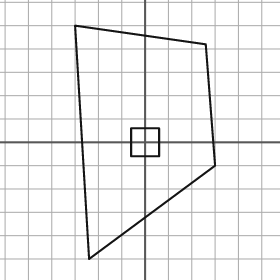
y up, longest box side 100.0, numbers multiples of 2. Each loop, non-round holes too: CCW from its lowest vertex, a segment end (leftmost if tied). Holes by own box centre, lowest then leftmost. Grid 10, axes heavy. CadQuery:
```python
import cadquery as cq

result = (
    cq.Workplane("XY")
    .moveTo(-24.0, -50.0)
    .lineTo(30.0, -10.0)
    .lineTo(26.0, 42.0)
    .lineTo(-30.0, 50.0)
    .close()
    .moveTo(-6.0, -6.0)
    .lineTo(6.0, -6.0)
    .lineTo(6.0, 6.0)
    .lineTo(-6.0, 6.0)
    .close()
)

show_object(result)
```